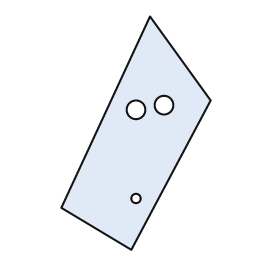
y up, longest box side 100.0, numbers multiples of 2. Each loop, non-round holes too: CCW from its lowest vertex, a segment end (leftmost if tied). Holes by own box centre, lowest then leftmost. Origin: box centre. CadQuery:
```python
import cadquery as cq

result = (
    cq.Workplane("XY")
    .moveTo(-2.0, -50.0)
    .lineTo(32.0, 14.0)
    .lineTo(6.0, 50.0)
    .lineTo(-32.0, -32.0)
    .close()
    .moveTo(0.0, -28.0)
    .circle(2.0)
    .moveTo(0.0, 10.0)
    .circle(4.0)
    .moveTo(12.0, 12.0)
    .circle(4.0)
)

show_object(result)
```